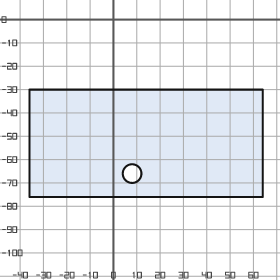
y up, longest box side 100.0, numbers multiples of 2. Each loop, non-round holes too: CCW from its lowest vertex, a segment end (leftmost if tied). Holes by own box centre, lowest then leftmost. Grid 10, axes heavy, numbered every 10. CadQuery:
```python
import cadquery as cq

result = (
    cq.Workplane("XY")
    .moveTo(-36.0, -76.0)
    .lineTo(64.0, -76.0)
    .lineTo(64.0, -30.0)
    .lineTo(-36.0, -30.0)
    .close()
    .moveTo(8.0, -66.0)
    .circle(4.0)
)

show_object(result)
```